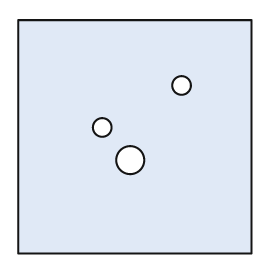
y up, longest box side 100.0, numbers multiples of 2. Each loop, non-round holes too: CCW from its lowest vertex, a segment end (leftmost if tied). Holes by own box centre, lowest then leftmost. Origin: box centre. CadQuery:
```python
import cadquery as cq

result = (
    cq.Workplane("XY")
    .moveTo(-50.0, -50.0)
    .lineTo(50.0, -50.0)
    .lineTo(50.0, 50.0)
    .lineTo(-50.0, 50.0)
    .close()
    .moveTo(-2.0, -10.0)
    .circle(6.0)
    .moveTo(-14.0, 4.0)
    .circle(4.0)
    .moveTo(20.0, 22.0)
    .circle(4.0)
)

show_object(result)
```